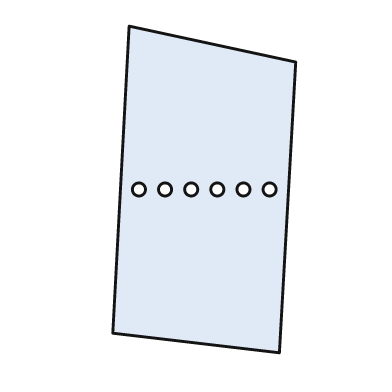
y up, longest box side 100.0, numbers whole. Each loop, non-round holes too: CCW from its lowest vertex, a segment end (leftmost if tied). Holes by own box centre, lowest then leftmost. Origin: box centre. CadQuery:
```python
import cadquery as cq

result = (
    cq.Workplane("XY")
    .moveTo(23.0, -50.0)
    .lineTo(28.0, 39.0)
    .lineTo(-23.0, 50.0)
    .lineTo(-28.0, -44.0)
    .close()
    .moveTo(-20.0, 0.0)
    .circle(2.0)
    .moveTo(-12.0, 0.0)
    .circle(2.0)
    .moveTo(-4.0, 0.0)
    .circle(2.0)
    .moveTo(4.0, 0.0)
    .circle(2.0)
    .moveTo(12.0, 0.0)
    .circle(2.0)
    .moveTo(20.0, 0.0)
    .circle(2.0)
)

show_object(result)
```